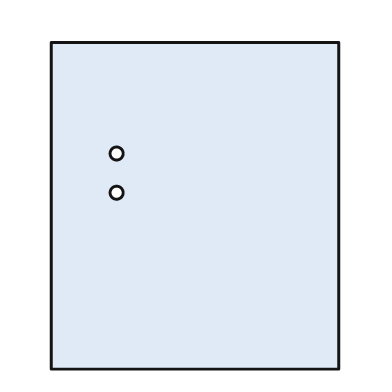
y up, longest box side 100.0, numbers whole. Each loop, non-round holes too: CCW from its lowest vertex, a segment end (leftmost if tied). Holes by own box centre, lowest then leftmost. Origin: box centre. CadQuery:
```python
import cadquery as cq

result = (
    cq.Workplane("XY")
    .moveTo(-44.0, -50.0)
    .lineTo(44.0, -50.0)
    .lineTo(44.0, 50.0)
    .lineTo(-44.0, 50.0)
    .close()
    .moveTo(-24.0, 4.0)
    .circle(2.0)
    .moveTo(-24.0, 16.0)
    .circle(2.0)
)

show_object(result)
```